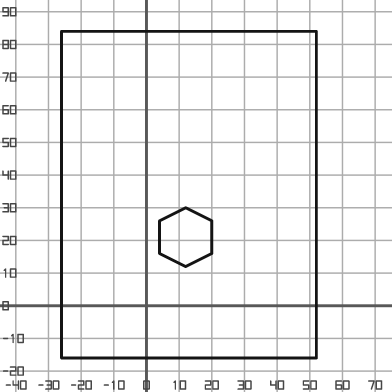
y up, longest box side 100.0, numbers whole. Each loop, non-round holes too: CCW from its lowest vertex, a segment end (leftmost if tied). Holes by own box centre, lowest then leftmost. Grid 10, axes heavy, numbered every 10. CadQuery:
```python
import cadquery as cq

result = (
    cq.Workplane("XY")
    .moveTo(-26.0, -16.0)
    .lineTo(52.0, -16.0)
    .lineTo(52.0, 84.0)
    .lineTo(-26.0, 84.0)
    .close()
    .moveTo(12.0, 12.0)
    .lineTo(20.0, 16.0)
    .lineTo(20.0, 26.0)
    .lineTo(12.0, 30.0)
    .lineTo(4.0, 26.0)
    .lineTo(4.0, 16.0)
    .close()
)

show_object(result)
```